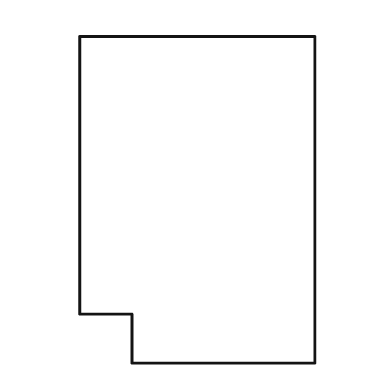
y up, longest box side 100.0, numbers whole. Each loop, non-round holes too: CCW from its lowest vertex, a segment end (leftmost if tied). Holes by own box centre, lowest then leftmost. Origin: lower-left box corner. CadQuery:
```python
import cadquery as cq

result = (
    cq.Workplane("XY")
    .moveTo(16.0, 0.0)
    .lineTo(72.0, 0.0)
    .lineTo(72.0, 100.0)
    .lineTo(0.0, 100.0)
    .lineTo(0.0, 15.0)
    .lineTo(16.0, 15.0)
    .close()
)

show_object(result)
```